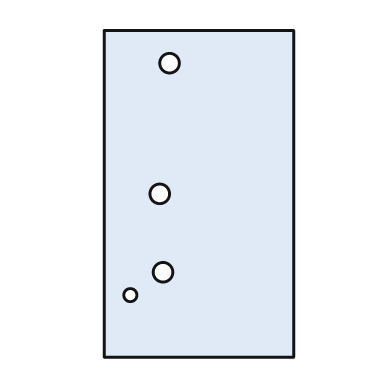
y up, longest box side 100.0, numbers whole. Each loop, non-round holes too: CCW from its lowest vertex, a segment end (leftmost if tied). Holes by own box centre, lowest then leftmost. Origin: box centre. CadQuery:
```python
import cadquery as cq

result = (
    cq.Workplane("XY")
    .moveTo(-29.0, -50.0)
    .lineTo(29.0, -50.0)
    .lineTo(29.0, 50.0)
    .lineTo(-29.0, 50.0)
    .close()
    .moveTo(-21.0, -31.0)
    .circle(2.0)
    .moveTo(-11.0, -24.0)
    .circle(3.0)
    .moveTo(-12.0, 0.0)
    .circle(3.0)
    .moveTo(-9.0, 40.0)
    .circle(3.0)
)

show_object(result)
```